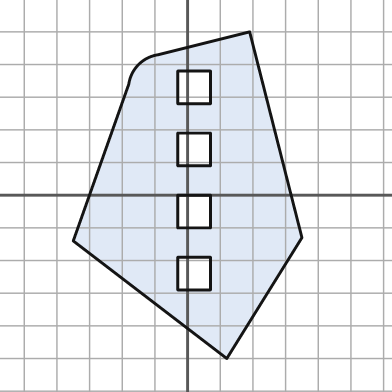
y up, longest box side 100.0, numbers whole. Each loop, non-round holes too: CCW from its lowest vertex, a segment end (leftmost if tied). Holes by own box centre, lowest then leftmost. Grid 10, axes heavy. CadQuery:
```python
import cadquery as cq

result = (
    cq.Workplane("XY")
    .moveTo(12.0, -50.0)
    .lineTo(35.0, -13.0)
    .lineTo(19.0, 50.0)
    .lineTo(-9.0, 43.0)
    .threePointArc((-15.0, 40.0), (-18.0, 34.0))
    .lineTo(-35.0, -14.0)
    .close()
    .moveTo(-3.0, -29.0)
    .lineTo(7.0, -29.0)
    .lineTo(7.0, -19.0)
    .lineTo(-3.0, -19.0)
    .close()
    .moveTo(-3.0, -10.0)
    .lineTo(7.0, -10.0)
    .lineTo(7.0, 0.0)
    .lineTo(-3.0, 0.0)
    .close()
    .moveTo(-3.0, 9.0)
    .lineTo(7.0, 9.0)
    .lineTo(7.0, 19.0)
    .lineTo(-3.0, 19.0)
    .close()
    .moveTo(-3.0, 28.0)
    .lineTo(7.0, 28.0)
    .lineTo(7.0, 38.0)
    .lineTo(-3.0, 38.0)
    .close()
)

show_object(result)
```